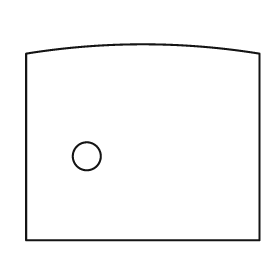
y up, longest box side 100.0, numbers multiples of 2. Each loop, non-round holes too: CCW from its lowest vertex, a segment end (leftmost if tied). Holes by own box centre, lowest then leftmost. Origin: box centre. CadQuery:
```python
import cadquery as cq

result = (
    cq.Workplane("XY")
    .moveTo(-50.0, -42.0)
    .lineTo(50.0, -42.0)
    .lineTo(50.0, 38.0)
    .threePointArc((0.0, 42.0), (-50.0, 38.0))
    .close()
    .moveTo(-24.0, -6.0)
    .circle(6.0)
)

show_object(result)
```